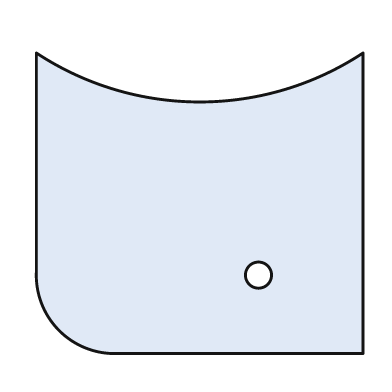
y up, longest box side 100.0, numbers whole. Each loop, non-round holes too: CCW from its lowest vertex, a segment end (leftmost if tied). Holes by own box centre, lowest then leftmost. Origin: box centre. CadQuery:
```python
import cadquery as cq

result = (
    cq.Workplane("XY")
    .moveTo(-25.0, -46.0)
    .lineTo(50.0, -46.0)
    .lineTo(50.0, 46.0)
    .threePointArc((0.0, 31.0), (-50.0, 46.0))
    .lineTo(-50.0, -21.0)
    .threePointArc((-43.0, -39.0), (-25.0, -46.0))
    .close()
    .moveTo(18.0, -22.0)
    .circle(4.0)
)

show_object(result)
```